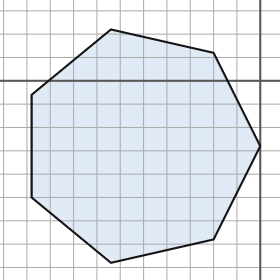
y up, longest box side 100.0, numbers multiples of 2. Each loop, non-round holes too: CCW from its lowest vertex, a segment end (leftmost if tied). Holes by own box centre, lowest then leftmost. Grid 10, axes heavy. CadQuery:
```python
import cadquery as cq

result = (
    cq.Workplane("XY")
    .moveTo(-64.0, -78.0)
    .lineTo(-20.0, -68.0)
    .lineTo(0.0, -28.0)
    .lineTo(-20.0, 12.0)
    .lineTo(-64.0, 22.0)
    .lineTo(-98.0, -6.0)
    .lineTo(-98.0, -50.0)
    .close()
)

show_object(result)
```